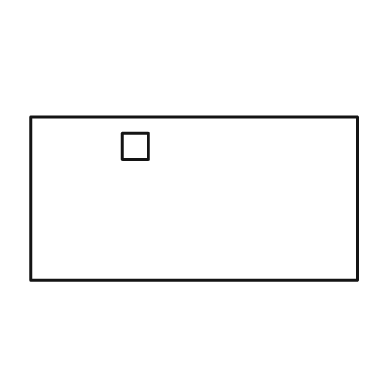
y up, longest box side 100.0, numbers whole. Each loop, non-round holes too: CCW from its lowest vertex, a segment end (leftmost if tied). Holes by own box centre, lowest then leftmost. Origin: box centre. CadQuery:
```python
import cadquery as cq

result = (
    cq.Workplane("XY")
    .moveTo(-50.0, -25.0)
    .lineTo(50.0, -25.0)
    .lineTo(50.0, 25.0)
    .lineTo(-50.0, 25.0)
    .close()
    .moveTo(-22.0, 12.0)
    .lineTo(-14.0, 12.0)
    .lineTo(-14.0, 20.0)
    .lineTo(-22.0, 20.0)
    .close()
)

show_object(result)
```